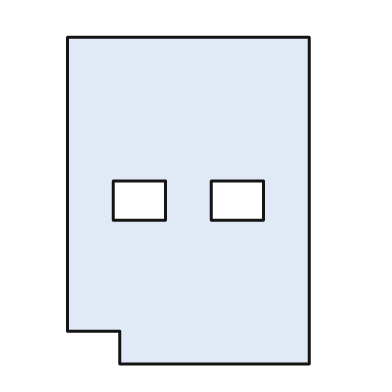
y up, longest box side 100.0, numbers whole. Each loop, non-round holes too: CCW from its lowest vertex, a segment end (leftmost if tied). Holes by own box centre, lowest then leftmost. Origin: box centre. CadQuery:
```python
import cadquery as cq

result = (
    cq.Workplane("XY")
    .moveTo(-21.0, -50.0)
    .lineTo(37.0, -50.0)
    .lineTo(37.0, 50.0)
    .lineTo(-37.0, 50.0)
    .lineTo(-37.0, -40.0)
    .lineTo(-21.0, -40.0)
    .close()
    .moveTo(-23.0, -6.0)
    .lineTo(-7.0, -6.0)
    .lineTo(-7.0, 6.0)
    .lineTo(-23.0, 6.0)
    .close()
    .moveTo(7.0, -6.0)
    .lineTo(23.0, -6.0)
    .lineTo(23.0, 6.0)
    .lineTo(7.0, 6.0)
    .close()
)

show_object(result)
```